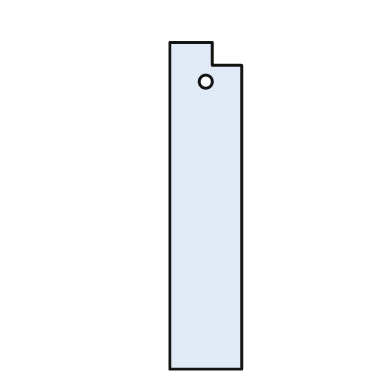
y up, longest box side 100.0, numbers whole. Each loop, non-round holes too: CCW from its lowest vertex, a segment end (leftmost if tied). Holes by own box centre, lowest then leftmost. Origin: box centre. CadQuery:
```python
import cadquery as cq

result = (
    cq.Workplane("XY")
    .moveTo(-11.0, -50.0)
    .lineTo(11.0, -50.0)
    .lineTo(11.0, 43.0)
    .lineTo(2.0, 43.0)
    .lineTo(2.0, 50.0)
    .lineTo(-11.0, 50.0)
    .close()
    .moveTo(0.0, 38.0)
    .circle(2.0)
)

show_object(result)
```